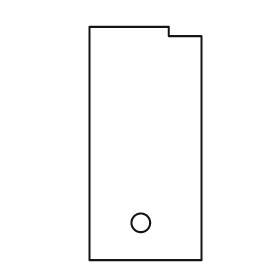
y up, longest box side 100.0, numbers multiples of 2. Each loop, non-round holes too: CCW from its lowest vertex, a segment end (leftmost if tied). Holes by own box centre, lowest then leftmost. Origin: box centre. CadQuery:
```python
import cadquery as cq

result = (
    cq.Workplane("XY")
    .moveTo(-24.0, -50.0)
    .lineTo(24.0, -50.0)
    .lineTo(24.0, 46.0)
    .lineTo(10.0, 46.0)
    .lineTo(10.0, 50.0)
    .lineTo(-24.0, 50.0)
    .close()
    .moveTo(-2.0, -34.0)
    .circle(4.0)
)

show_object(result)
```